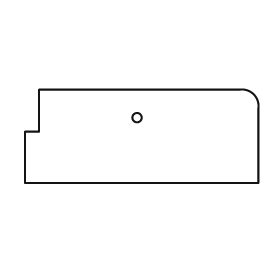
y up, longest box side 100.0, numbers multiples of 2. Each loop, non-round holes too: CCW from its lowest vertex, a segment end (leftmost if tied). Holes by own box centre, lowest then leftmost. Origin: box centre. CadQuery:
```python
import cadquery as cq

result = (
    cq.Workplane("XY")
    .moveTo(-50.0, -20.0)
    .lineTo(50.0, -20.0)
    .lineTo(50.0, 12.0)
    .threePointArc((48.0, 18.0), (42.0, 20.0))
    .lineTo(-44.0, 20.0)
    .lineTo(-44.0, 2.0)
    .lineTo(-50.0, 2.0)
    .close()
    .moveTo(-2.0, 8.0)
    .circle(2.0)
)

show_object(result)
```